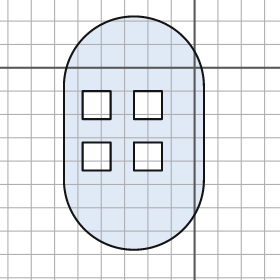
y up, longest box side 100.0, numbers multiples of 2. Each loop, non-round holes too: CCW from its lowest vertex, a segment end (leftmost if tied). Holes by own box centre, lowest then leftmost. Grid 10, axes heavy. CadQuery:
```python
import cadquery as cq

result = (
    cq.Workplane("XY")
    .moveTo(-56.0, -48.0)
    .threePointArc((-26.0, -78.0), (4.0, -48.0))
    .lineTo(4.0, -8.0)
    .threePointArc((-26.0, 22.0), (-56.0, -8.0))
    .close()
    .moveTo(-48.0, -44.0)
    .lineTo(-36.0, -44.0)
    .lineTo(-36.0, -32.0)
    .lineTo(-48.0, -32.0)
    .close()
    .moveTo(-26.0, -44.0)
    .lineTo(-14.0, -44.0)
    .lineTo(-14.0, -32.0)
    .lineTo(-26.0, -32.0)
    .close()
    .moveTo(-48.0, -22.0)
    .lineTo(-36.0, -22.0)
    .lineTo(-36.0, -10.0)
    .lineTo(-48.0, -10.0)
    .close()
    .moveTo(-26.0, -22.0)
    .lineTo(-14.0, -22.0)
    .lineTo(-14.0, -10.0)
    .lineTo(-26.0, -10.0)
    .close()
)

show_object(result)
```